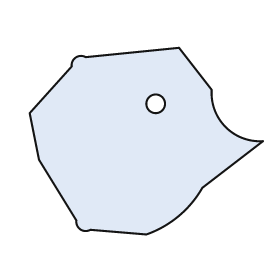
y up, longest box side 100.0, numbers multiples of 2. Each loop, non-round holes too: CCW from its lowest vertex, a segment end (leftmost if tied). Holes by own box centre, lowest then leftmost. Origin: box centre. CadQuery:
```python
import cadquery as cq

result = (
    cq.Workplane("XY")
    .moveTo(0.0, -40.0)
    .threePointArc((14.0, -32.0), (24.0, -20.0))
    .lineTo(50.0, 0.0)
    .threePointArc((34.0, 6.0), (28.0, 22.0))
    .lineTo(14.0, 40.0)
    .lineTo(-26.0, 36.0)
    .threePointArc((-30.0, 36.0), (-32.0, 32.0))
    .lineTo(-50.0, 12.0)
    .lineTo(-46.0, -8.0)
    .lineTo(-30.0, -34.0)
    .threePointArc((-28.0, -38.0), (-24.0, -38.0))
    .close()
    .moveTo(4.0, 16.0)
    .circle(4.0)
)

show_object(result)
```